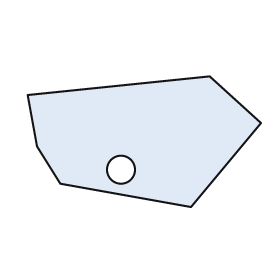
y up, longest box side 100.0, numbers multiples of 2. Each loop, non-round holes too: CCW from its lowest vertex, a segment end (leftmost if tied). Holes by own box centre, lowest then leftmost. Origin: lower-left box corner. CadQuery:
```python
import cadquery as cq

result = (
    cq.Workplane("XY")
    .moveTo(70.0, 0.0)
    .lineTo(100.0, 36.0)
    .lineTo(78.0, 56.0)
    .lineTo(0.0, 48.0)
    .lineTo(4.0, 26.0)
    .lineTo(14.0, 10.0)
    .close()
    .moveTo(40.0, 16.0)
    .circle(6.0)
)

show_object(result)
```